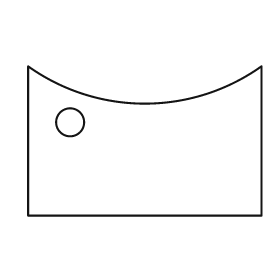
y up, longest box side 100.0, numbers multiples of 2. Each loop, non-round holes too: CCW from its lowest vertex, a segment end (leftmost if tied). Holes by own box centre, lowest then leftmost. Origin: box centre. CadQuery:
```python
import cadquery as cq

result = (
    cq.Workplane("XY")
    .moveTo(-50.0, -32.0)
    .lineTo(50.0, -32.0)
    .lineTo(50.0, 32.0)
    .threePointArc((0.0, 16.0), (-50.0, 32.0))
    .close()
    .moveTo(-32.0, 8.0)
    .circle(6.0)
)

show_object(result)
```